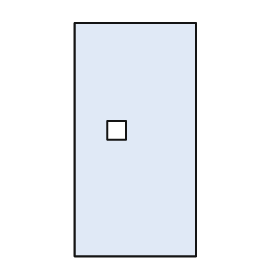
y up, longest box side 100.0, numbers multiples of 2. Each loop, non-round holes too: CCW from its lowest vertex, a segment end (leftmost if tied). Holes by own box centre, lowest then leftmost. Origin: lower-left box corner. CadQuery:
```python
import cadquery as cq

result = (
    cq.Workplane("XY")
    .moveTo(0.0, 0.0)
    .lineTo(52.0, 0.0)
    .lineTo(52.0, 100.0)
    .lineTo(0.0, 100.0)
    .close()
    .moveTo(14.0, 50.0)
    .lineTo(22.0, 50.0)
    .lineTo(22.0, 58.0)
    .lineTo(14.0, 58.0)
    .close()
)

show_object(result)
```